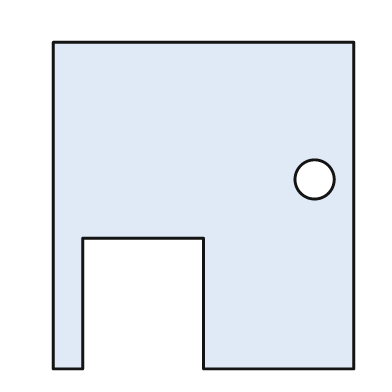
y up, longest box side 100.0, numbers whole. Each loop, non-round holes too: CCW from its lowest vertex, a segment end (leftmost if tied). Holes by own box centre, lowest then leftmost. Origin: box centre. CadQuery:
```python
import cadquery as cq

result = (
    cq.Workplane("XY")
    .moveTo(-46.0, -50.0)
    .lineTo(-37.0, -50.0)
    .lineTo(-37.0, -10.0)
    .lineTo(0.0, -10.0)
    .lineTo(0.0, -50.0)
    .lineTo(46.0, -50.0)
    .lineTo(46.0, 50.0)
    .lineTo(-46.0, 50.0)
    .close()
    .moveTo(34.0, 8.0)
    .circle(6.0)
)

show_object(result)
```